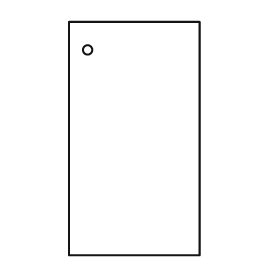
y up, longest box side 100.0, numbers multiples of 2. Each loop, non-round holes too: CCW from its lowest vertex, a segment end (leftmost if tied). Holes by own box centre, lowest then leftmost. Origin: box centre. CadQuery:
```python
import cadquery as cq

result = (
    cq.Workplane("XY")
    .moveTo(-28.0, -50.0)
    .lineTo(28.0, -50.0)
    .lineTo(28.0, 50.0)
    .lineTo(-28.0, 50.0)
    .close()
    .moveTo(-20.0, 38.0)
    .circle(2.0)
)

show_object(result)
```